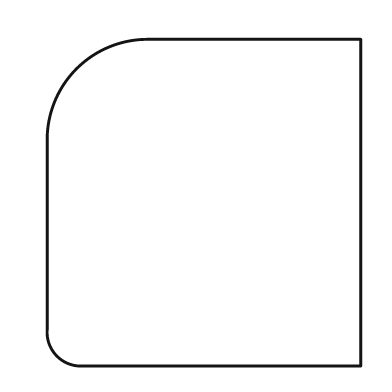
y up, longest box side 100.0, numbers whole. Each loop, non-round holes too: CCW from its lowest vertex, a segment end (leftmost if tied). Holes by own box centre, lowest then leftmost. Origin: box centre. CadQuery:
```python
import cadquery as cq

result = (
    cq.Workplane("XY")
    .moveTo(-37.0, -50.0)
    .lineTo(48.0, -50.0)
    .lineTo(48.0, 50.0)
    .lineTo(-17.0, 50.0)
    .threePointArc((-39.0, 41.0), (-48.0, 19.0))
    .lineTo(-48.0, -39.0)
    .threePointArc((-45.0, -47.0), (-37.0, -50.0))
    .close()
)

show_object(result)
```